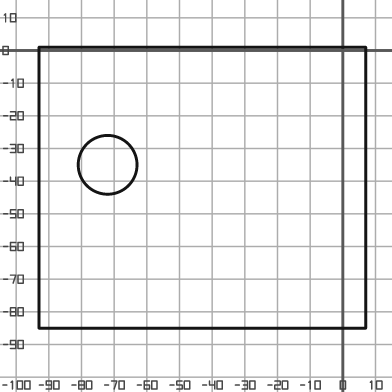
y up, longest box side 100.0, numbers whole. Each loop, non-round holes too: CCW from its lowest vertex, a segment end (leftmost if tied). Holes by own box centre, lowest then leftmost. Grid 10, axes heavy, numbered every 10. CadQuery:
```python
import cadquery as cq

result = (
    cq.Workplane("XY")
    .moveTo(-93.0, -85.0)
    .lineTo(7.0, -85.0)
    .lineTo(7.0, 1.0)
    .lineTo(-93.0, 1.0)
    .close()
    .moveTo(-72.0, -35.0)
    .circle(9.0)
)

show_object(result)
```